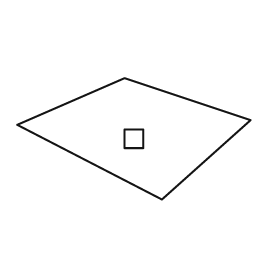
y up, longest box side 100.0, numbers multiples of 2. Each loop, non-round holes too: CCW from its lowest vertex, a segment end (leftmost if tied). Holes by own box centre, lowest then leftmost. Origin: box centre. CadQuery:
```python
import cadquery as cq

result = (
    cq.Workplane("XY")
    .moveTo(12.0, -26.0)
    .lineTo(50.0, 8.0)
    .lineTo(-4.0, 26.0)
    .lineTo(-50.0, 6.0)
    .close()
    .moveTo(-4.0, -4.0)
    .lineTo(4.0, -4.0)
    .lineTo(4.0, 4.0)
    .lineTo(-4.0, 4.0)
    .close()
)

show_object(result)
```